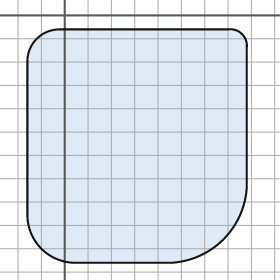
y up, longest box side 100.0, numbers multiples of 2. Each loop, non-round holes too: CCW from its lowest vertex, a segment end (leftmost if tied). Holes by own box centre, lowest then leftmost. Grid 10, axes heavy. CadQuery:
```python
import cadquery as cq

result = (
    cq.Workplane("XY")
    .moveTo(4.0, -106.0)
    .lineTo(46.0, -106.0)
    .threePointArc((68.0, -96.0), (78.0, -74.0))
    .lineTo(78.0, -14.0)
    .threePointArc((76.0, -8.0), (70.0, -6.0))
    .lineTo(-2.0, -6.0)
    .threePointArc((-12.0, -10.0), (-16.0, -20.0))
    .lineTo(-16.0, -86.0)
    .threePointArc((-10.0, -100.0), (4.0, -106.0))
    .close()
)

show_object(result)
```